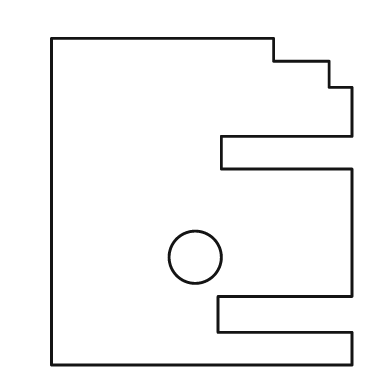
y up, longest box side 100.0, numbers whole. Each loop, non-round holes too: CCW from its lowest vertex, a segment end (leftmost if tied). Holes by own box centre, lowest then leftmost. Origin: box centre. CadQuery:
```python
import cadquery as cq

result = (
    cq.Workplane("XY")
    .moveTo(-46.0, -50.0)
    .lineTo(46.0, -50.0)
    .lineTo(46.0, -40.0)
    .lineTo(5.0, -40.0)
    .lineTo(5.0, -29.0)
    .lineTo(46.0, -29.0)
    .lineTo(46.0, 10.0)
    .lineTo(6.0, 10.0)
    .lineTo(6.0, 20.0)
    .lineTo(46.0, 20.0)
    .lineTo(46.0, 35.0)
    .lineTo(39.0, 35.0)
    .lineTo(39.0, 43.0)
    .lineTo(22.0, 43.0)
    .lineTo(22.0, 50.0)
    .lineTo(-46.0, 50.0)
    .close()
    .moveTo(-2.0, -17.0)
    .circle(8.0)
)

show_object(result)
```